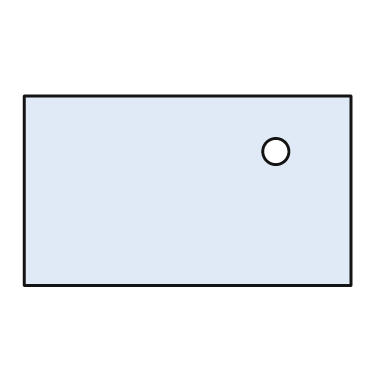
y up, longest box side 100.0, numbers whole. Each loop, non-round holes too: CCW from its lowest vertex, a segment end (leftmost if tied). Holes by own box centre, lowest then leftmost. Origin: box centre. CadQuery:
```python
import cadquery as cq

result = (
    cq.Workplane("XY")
    .moveTo(-50.0, -29.0)
    .lineTo(50.0, -29.0)
    .lineTo(50.0, 29.0)
    .lineTo(-50.0, 29.0)
    .close()
    .moveTo(27.0, 12.0)
    .circle(4.0)
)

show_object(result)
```